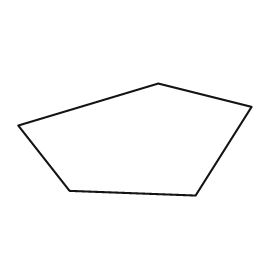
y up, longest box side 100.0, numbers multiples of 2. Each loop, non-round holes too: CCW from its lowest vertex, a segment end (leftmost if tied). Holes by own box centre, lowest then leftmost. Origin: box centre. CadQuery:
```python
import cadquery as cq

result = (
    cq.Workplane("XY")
    .moveTo(26.0, -24.0)
    .lineTo(50.0, 14.0)
    .lineTo(10.0, 24.0)
    .lineTo(-50.0, 6.0)
    .lineTo(-28.0, -22.0)
    .close()
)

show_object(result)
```